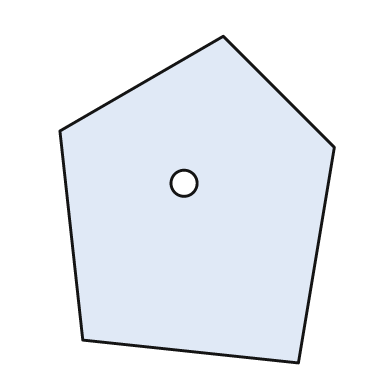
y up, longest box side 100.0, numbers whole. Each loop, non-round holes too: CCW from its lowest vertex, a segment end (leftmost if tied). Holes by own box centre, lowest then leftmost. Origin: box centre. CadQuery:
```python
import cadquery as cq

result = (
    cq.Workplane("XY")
    .moveTo(31.0, -50.0)
    .lineTo(42.0, 16.0)
    .lineTo(8.0, 50.0)
    .lineTo(-42.0, 21.0)
    .lineTo(-35.0, -43.0)
    .close()
    .moveTo(-4.0, 5.0)
    .circle(4.0)
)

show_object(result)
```